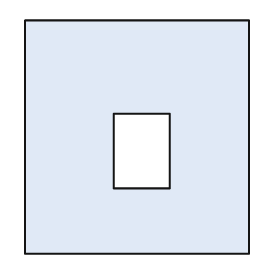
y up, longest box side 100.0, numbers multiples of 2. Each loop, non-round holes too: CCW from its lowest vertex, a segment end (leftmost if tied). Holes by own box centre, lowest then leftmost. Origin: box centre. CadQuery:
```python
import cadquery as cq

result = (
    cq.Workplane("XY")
    .moveTo(-48.0, -50.0)
    .lineTo(48.0, -50.0)
    .lineTo(48.0, 50.0)
    .lineTo(-48.0, 50.0)
    .close()
    .moveTo(-10.0, -22.0)
    .lineTo(14.0, -22.0)
    .lineTo(14.0, 10.0)
    .lineTo(-10.0, 10.0)
    .close()
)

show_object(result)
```